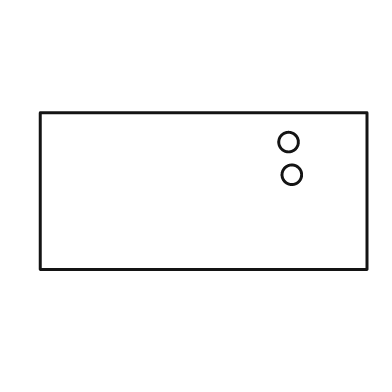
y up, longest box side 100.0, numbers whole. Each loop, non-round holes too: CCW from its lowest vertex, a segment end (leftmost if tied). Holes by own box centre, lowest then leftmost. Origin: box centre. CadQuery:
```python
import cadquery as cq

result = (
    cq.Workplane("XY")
    .moveTo(-50.0, -24.0)
    .lineTo(50.0, -24.0)
    .lineTo(50.0, 24.0)
    .lineTo(-50.0, 24.0)
    .close()
    .moveTo(27.0, 5.0)
    .circle(3.0)
    .moveTo(26.0, 15.0)
    .circle(3.0)
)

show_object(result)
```